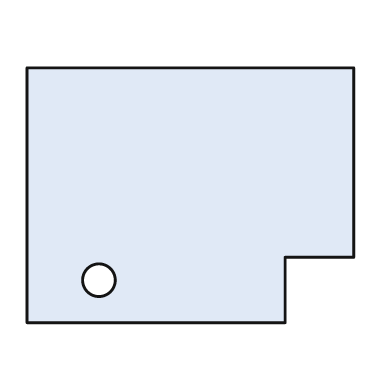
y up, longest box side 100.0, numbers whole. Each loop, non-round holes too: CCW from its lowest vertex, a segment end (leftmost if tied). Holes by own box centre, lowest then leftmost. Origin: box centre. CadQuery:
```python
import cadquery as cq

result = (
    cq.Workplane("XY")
    .moveTo(-50.0, -39.0)
    .lineTo(29.0, -39.0)
    .lineTo(29.0, -19.0)
    .lineTo(50.0, -19.0)
    .lineTo(50.0, 39.0)
    .lineTo(-50.0, 39.0)
    .close()
    .moveTo(-28.0, -26.0)
    .circle(5.0)
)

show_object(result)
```